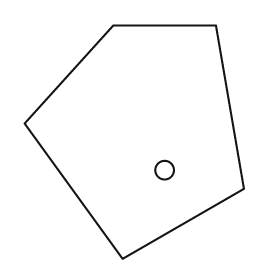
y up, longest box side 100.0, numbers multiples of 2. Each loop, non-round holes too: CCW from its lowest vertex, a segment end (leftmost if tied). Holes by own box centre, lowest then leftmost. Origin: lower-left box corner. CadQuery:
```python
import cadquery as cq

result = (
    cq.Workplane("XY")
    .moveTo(42.0, 0.0)
    .lineTo(94.0, 30.0)
    .lineTo(82.0, 100.0)
    .lineTo(38.0, 100.0)
    .lineTo(0.0, 58.0)
    .close()
    .moveTo(60.0, 38.0)
    .circle(4.0)
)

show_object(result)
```